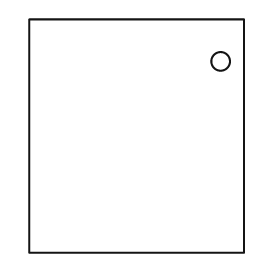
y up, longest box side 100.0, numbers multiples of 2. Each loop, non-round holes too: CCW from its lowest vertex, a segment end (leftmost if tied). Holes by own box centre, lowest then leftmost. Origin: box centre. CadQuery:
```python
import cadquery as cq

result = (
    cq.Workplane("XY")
    .moveTo(-46.0, -50.0)
    .lineTo(46.0, -50.0)
    .lineTo(46.0, 50.0)
    .lineTo(-46.0, 50.0)
    .close()
    .moveTo(36.0, 32.0)
    .circle(4.0)
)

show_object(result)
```